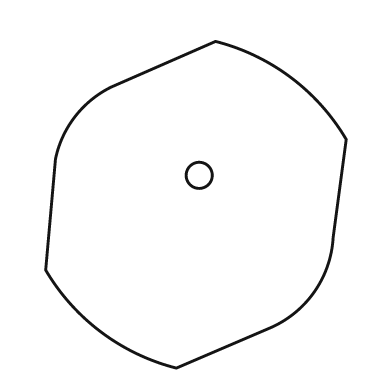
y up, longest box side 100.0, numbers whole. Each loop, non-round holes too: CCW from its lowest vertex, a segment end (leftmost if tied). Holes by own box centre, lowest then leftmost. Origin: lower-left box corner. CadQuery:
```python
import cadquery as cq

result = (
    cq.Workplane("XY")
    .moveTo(40.0, 0.0)
    .lineTo(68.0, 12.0)
    .threePointArc((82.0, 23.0), (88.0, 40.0))
    .lineTo(92.0, 70.0)
    .threePointArc((75.0, 89.0), (52.0, 100.0))
    .lineTo(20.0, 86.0)
    .threePointArc((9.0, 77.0), (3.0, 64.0))
    .lineTo(0.0, 30.0)
    .threePointArc((17.0, 11.0), (40.0, 0.0))
    .close()
    .moveTo(47.0, 59.0)
    .circle(4.0)
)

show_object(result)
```